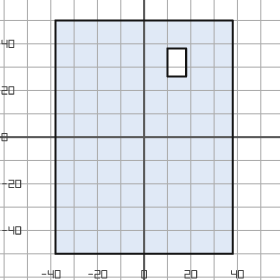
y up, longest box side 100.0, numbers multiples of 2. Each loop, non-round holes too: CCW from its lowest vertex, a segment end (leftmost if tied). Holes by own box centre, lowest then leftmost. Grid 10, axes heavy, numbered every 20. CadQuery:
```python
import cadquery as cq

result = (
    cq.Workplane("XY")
    .moveTo(-38.0, -50.0)
    .lineTo(38.0, -50.0)
    .lineTo(38.0, 50.0)
    .lineTo(-38.0, 50.0)
    .close()
    .moveTo(10.0, 26.0)
    .lineTo(18.0, 26.0)
    .lineTo(18.0, 38.0)
    .lineTo(10.0, 38.0)
    .close()
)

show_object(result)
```